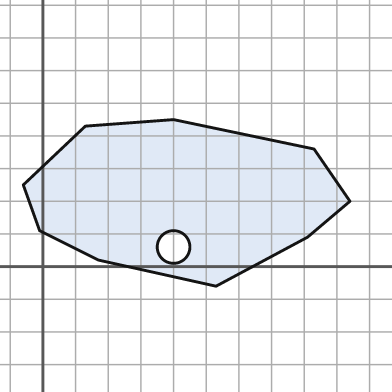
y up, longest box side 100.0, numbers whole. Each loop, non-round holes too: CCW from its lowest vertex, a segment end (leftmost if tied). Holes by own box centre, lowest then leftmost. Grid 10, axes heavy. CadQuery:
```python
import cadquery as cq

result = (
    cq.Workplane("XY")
    .moveTo(53.0, -6.0)
    .lineTo(81.0, 9.0)
    .lineTo(94.0, 20.0)
    .lineTo(83.0, 36.0)
    .lineTo(40.0, 45.0)
    .lineTo(13.0, 43.0)
    .lineTo(-6.0, 25.0)
    .lineTo(-1.0, 11.0)
    .lineTo(17.0, 2.0)
    .close()
    .moveTo(40.0, 6.0)
    .circle(5.0)
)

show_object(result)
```